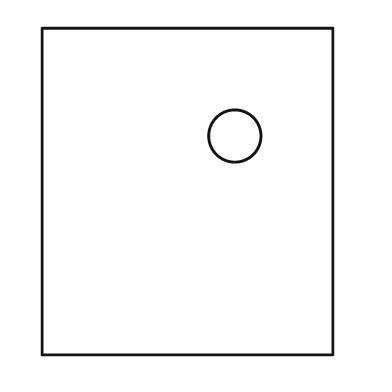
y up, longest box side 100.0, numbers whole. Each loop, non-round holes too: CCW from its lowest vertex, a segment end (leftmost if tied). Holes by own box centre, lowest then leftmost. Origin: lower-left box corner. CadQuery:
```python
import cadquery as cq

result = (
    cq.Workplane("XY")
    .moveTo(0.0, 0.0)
    .lineTo(89.0, 0.0)
    .lineTo(89.0, 100.0)
    .lineTo(0.0, 100.0)
    .close()
    .moveTo(59.0, 67.0)
    .circle(8.0)
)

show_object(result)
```